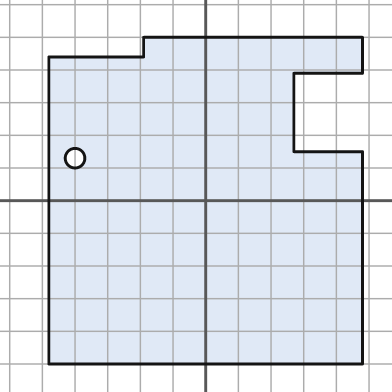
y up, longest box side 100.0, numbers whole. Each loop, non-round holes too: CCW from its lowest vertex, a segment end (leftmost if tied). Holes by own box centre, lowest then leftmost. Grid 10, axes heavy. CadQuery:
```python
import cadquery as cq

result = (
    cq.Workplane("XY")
    .moveTo(-48.0, -50.0)
    .lineTo(48.0, -50.0)
    .lineTo(48.0, 15.0)
    .lineTo(27.0, 15.0)
    .lineTo(27.0, 39.0)
    .lineTo(48.0, 39.0)
    .lineTo(48.0, 50.0)
    .lineTo(-19.0, 50.0)
    .lineTo(-19.0, 44.0)
    .lineTo(-48.0, 44.0)
    .close()
    .moveTo(-40.0, 13.0)
    .circle(3.0)
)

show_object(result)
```